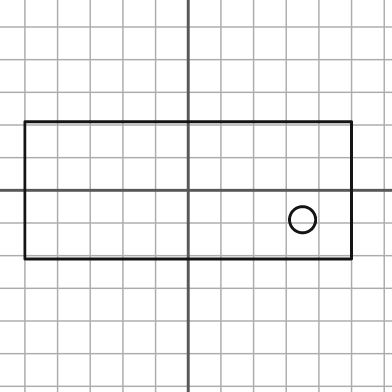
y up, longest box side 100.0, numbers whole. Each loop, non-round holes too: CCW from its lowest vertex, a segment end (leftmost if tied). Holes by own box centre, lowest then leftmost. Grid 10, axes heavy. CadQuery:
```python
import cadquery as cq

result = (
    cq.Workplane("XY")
    .moveTo(-50.0, -21.0)
    .lineTo(50.0, -21.0)
    .lineTo(50.0, 21.0)
    .lineTo(-50.0, 21.0)
    .close()
    .moveTo(35.0, -9.0)
    .circle(4.0)
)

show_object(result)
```